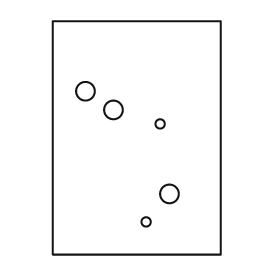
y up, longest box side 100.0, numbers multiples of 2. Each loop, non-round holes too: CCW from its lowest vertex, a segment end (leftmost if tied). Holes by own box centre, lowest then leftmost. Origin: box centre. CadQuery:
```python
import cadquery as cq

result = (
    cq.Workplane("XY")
    .moveTo(-36.0, -50.0)
    .lineTo(36.0, -50.0)
    .lineTo(36.0, 50.0)
    .lineTo(-36.0, 50.0)
    .close()
    .moveTo(4.0, -36.0)
    .circle(2.0)
    .moveTo(14.0, -24.0)
    .circle(4.0)
    .moveTo(10.0, 6.0)
    .circle(2.0)
    .moveTo(-10.0, 12.0)
    .circle(4.0)
    .moveTo(-22.0, 20.0)
    .circle(4.0)
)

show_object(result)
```